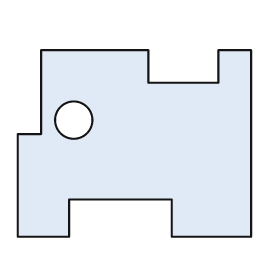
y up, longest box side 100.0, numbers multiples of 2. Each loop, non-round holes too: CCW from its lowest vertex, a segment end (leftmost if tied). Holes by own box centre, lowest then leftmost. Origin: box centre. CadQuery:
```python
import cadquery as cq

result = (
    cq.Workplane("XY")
    .moveTo(-50.0, -40.0)
    .lineTo(-28.0, -40.0)
    .lineTo(-28.0, -24.0)
    .lineTo(16.0, -24.0)
    .lineTo(16.0, -40.0)
    .lineTo(50.0, -40.0)
    .lineTo(50.0, 40.0)
    .lineTo(36.0, 40.0)
    .lineTo(36.0, 26.0)
    .lineTo(6.0, 26.0)
    .lineTo(6.0, 40.0)
    .lineTo(-40.0, 40.0)
    .lineTo(-40.0, 4.0)
    .lineTo(-50.0, 4.0)
    .close()
    .moveTo(-26.0, 10.0)
    .circle(8.0)
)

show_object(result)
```